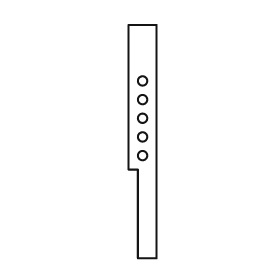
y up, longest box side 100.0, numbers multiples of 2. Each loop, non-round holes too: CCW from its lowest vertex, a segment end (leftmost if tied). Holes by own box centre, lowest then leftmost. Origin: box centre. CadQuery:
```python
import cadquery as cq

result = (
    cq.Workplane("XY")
    .moveTo(-2.0, -50.0)
    .lineTo(6.0, -50.0)
    .lineTo(6.0, 50.0)
    .lineTo(-6.0, 50.0)
    .lineTo(-6.0, -12.0)
    .lineTo(-2.0, -12.0)
    .close()
    .moveTo(0.0, -6.0)
    .circle(2.0)
    .moveTo(0.0, 2.0)
    .circle(2.0)
    .moveTo(0.0, 10.0)
    .circle(2.0)
    .moveTo(0.0, 18.0)
    .circle(2.0)
    .moveTo(0.0, 26.0)
    .circle(2.0)
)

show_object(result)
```